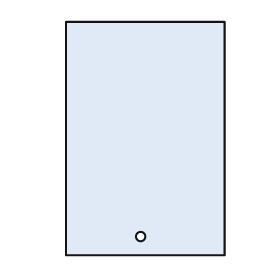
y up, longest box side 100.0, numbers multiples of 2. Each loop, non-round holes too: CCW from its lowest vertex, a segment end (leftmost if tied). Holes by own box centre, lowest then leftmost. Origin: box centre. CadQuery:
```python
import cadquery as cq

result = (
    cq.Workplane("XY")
    .moveTo(-34.0, -50.0)
    .lineTo(34.0, -50.0)
    .lineTo(34.0, 50.0)
    .lineTo(-34.0, 50.0)
    .close()
    .moveTo(-2.0, -42.0)
    .circle(2.0)
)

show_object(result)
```